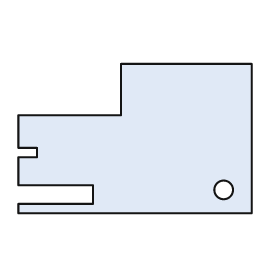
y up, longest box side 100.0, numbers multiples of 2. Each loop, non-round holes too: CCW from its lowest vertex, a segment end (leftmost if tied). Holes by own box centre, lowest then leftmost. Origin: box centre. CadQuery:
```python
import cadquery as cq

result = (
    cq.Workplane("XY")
    .moveTo(-50.0, -32.0)
    .lineTo(50.0, -32.0)
    .lineTo(50.0, 32.0)
    .lineTo(-6.0, 32.0)
    .lineTo(-6.0, 10.0)
    .lineTo(-50.0, 10.0)
    .lineTo(-50.0, -4.0)
    .lineTo(-42.0, -4.0)
    .lineTo(-42.0, -8.0)
    .lineTo(-50.0, -8.0)
    .lineTo(-50.0, -20.0)
    .lineTo(-18.0, -20.0)
    .lineTo(-18.0, -28.0)
    .lineTo(-50.0, -28.0)
    .close()
    .moveTo(38.0, -22.0)
    .circle(4.0)
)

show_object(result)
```